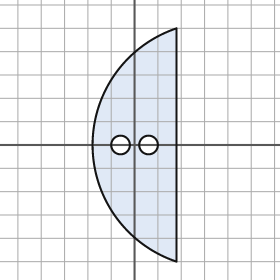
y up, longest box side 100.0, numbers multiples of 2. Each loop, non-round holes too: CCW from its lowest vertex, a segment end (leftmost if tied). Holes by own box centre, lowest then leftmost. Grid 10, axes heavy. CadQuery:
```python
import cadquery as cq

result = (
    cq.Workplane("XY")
    .moveTo(18.0, -50.0)
    .lineTo(18.0, 50.0)
    .threePointArc((-18.0, 0.0), (18.0, -50.0))
    .close()
    .moveTo(-6.0, 0.0)
    .circle(4.0)
    .moveTo(6.0, 0.0)
    .circle(4.0)
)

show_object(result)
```